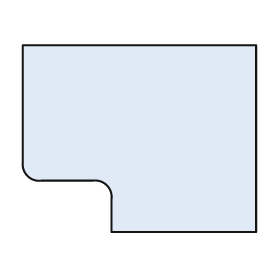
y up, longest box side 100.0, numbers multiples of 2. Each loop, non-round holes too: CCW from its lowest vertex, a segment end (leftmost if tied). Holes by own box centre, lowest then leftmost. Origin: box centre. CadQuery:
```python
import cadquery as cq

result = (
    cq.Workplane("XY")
    .moveTo(-12.0, -40.0)
    .lineTo(50.0, -40.0)
    .lineTo(50.0, 40.0)
    .lineTo(-50.0, 40.0)
    .lineTo(-50.0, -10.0)
    .threePointArc((-48.0, -16.0), (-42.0, -18.0))
    .lineTo(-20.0, -18.0)
    .threePointArc((-14.0, -20.0), (-12.0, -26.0))
    .close()
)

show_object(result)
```